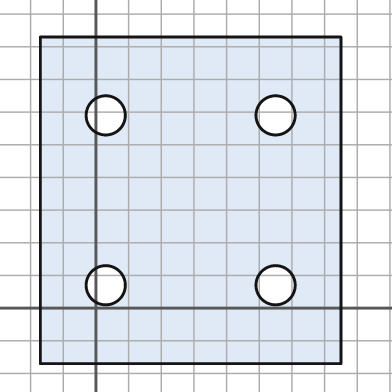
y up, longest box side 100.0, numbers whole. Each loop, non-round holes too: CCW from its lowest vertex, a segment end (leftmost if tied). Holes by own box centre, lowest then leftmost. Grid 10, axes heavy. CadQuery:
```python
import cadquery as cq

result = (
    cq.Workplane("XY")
    .moveTo(-17.0, -17.0)
    .lineTo(75.0, -17.0)
    .lineTo(75.0, 83.0)
    .lineTo(-17.0, 83.0)
    .close()
    .moveTo(3.0, 7.0)
    .circle(6.0)
    .moveTo(55.0, 7.0)
    .circle(6.0)
    .moveTo(3.0, 59.0)
    .circle(6.0)
    .moveTo(55.0, 59.0)
    .circle(6.0)
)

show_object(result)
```